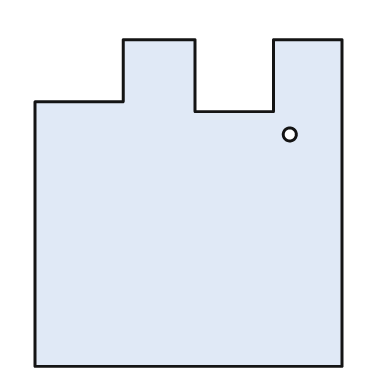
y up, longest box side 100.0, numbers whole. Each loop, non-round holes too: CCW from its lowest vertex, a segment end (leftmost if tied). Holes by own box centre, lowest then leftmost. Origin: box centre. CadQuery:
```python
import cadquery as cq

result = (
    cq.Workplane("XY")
    .moveTo(-47.0, -50.0)
    .lineTo(47.0, -50.0)
    .lineTo(47.0, 50.0)
    .lineTo(26.0, 50.0)
    .lineTo(26.0, 28.0)
    .lineTo(2.0, 28.0)
    .lineTo(2.0, 50.0)
    .lineTo(-20.0, 50.0)
    .lineTo(-20.0, 31.0)
    .lineTo(-47.0, 31.0)
    .close()
    .moveTo(31.0, 21.0)
    .circle(2.0)
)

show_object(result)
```